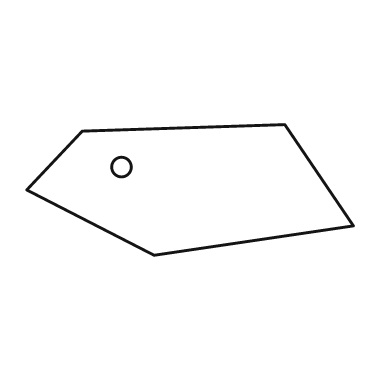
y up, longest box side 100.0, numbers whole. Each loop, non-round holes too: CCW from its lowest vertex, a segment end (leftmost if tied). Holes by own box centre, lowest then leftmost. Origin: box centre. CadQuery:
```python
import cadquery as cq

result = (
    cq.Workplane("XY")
    .moveTo(-11.0, -20.0)
    .lineTo(50.0, -11.0)
    .lineTo(29.0, 20.0)
    .lineTo(-33.0, 18.0)
    .lineTo(-50.0, 0.0)
    .close()
    .moveTo(-21.0, 7.0)
    .circle(3.0)
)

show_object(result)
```